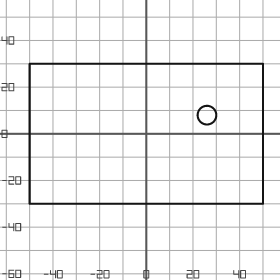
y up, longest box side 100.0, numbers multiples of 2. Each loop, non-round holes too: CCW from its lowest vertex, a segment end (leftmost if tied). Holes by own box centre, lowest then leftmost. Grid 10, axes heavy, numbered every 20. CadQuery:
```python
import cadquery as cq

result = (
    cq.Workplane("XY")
    .moveTo(-50.0, -30.0)
    .lineTo(50.0, -30.0)
    .lineTo(50.0, 30.0)
    .lineTo(-50.0, 30.0)
    .close()
    .moveTo(26.0, 8.0)
    .circle(4.0)
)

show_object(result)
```